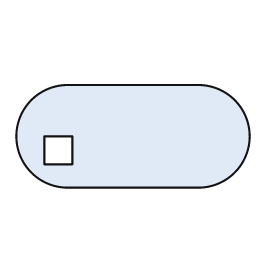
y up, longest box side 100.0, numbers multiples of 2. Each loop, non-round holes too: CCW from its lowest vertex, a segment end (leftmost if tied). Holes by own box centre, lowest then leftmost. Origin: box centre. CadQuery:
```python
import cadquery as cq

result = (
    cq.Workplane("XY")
    .moveTo(-28.0, -22.0)
    .lineTo(28.0, -22.0)
    .threePointArc((50.0, 0.0), (28.0, 22.0))
    .lineTo(-28.0, 22.0)
    .threePointArc((-50.0, 0.0), (-28.0, -22.0))
    .close()
    .moveTo(-38.0, -12.0)
    .lineTo(-26.0, -12.0)
    .lineTo(-26.0, 0.0)
    .lineTo(-38.0, 0.0)
    .close()
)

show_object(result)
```